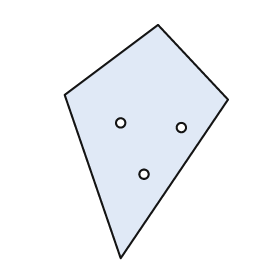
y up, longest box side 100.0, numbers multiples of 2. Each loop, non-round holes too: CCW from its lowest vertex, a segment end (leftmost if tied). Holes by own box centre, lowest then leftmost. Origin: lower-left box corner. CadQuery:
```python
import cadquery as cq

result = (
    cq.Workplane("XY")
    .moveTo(24.0, 0.0)
    .lineTo(70.0, 68.0)
    .lineTo(40.0, 100.0)
    .lineTo(0.0, 70.0)
    .close()
    .moveTo(34.0, 36.0)
    .circle(2.0)
    .moveTo(50.0, 56.0)
    .circle(2.0)
    .moveTo(24.0, 58.0)
    .circle(2.0)
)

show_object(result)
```